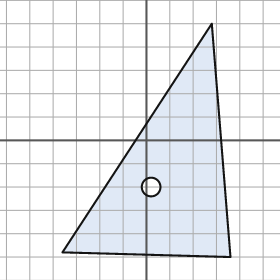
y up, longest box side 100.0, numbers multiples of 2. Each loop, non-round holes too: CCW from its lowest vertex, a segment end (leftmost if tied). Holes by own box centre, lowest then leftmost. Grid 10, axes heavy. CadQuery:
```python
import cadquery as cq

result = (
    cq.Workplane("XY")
    .moveTo(36.0, -50.0)
    .lineTo(28.0, 50.0)
    .lineTo(-36.0, -48.0)
    .close()
    .moveTo(2.0, -20.0)
    .circle(4.0)
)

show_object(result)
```